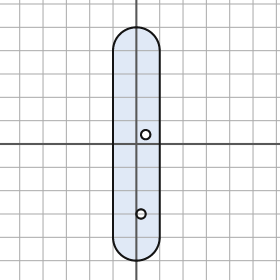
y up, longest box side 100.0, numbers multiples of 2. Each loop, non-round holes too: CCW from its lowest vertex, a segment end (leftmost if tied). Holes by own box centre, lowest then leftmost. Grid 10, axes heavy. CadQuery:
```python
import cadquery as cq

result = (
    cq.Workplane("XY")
    .moveTo(-10.0, -40.0)
    .threePointArc((0.0, -50.0), (10.0, -40.0))
    .lineTo(10.0, 40.0)
    .threePointArc((0.0, 50.0), (-10.0, 40.0))
    .close()
    .moveTo(2.0, -30.0)
    .circle(2.0)
    .moveTo(4.0, 4.0)
    .circle(2.0)
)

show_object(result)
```